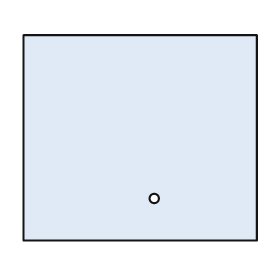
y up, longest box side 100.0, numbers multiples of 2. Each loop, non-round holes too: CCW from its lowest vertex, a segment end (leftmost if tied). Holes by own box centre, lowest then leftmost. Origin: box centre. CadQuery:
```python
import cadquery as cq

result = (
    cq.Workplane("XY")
    .moveTo(-50.0, -44.0)
    .lineTo(50.0, -44.0)
    .lineTo(50.0, 44.0)
    .lineTo(-50.0, 44.0)
    .close()
    .moveTo(6.0, -26.0)
    .circle(2.0)
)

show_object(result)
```